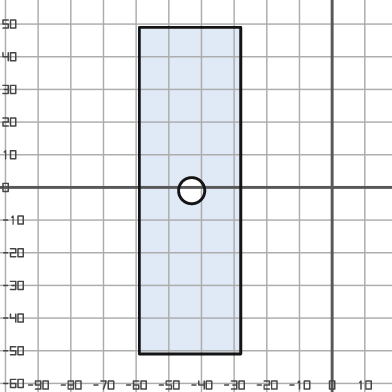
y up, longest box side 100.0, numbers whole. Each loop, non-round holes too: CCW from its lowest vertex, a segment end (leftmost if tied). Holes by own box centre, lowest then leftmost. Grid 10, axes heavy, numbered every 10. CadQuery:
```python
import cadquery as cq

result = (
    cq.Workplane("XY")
    .moveTo(-59.0, -51.0)
    .lineTo(-28.0, -51.0)
    .lineTo(-28.0, 49.0)
    .lineTo(-59.0, 49.0)
    .close()
    .moveTo(-43.0, -1.0)
    .circle(4.0)
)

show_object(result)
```